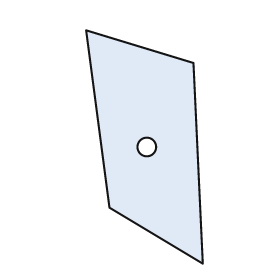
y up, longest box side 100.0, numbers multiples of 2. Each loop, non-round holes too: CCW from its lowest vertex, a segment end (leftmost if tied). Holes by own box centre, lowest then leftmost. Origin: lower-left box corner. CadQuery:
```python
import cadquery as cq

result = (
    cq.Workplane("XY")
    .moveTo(50.0, 0.0)
    .lineTo(46.0, 86.0)
    .lineTo(0.0, 100.0)
    .lineTo(10.0, 24.0)
    .close()
    .moveTo(26.0, 50.0)
    .circle(4.0)
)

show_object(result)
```